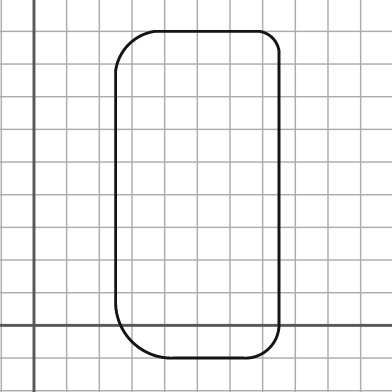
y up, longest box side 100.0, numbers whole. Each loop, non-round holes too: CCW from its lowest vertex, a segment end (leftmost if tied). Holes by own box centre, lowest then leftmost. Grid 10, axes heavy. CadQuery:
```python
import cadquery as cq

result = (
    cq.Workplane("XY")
    .moveTo(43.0, -10.0)
    .lineTo(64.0, -10.0)
    .threePointArc((72.0, -7.0), (75.0, 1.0))
    .lineTo(75.0, 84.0)
    .threePointArc((73.0, 88.0), (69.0, 90.0))
    .lineTo(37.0, 90.0)
    .threePointArc((29.0, 86.0), (25.0, 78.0))
    .lineTo(25.0, 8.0)
    .threePointArc((30.0, -5.0), (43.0, -10.0))
    .close()
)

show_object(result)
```